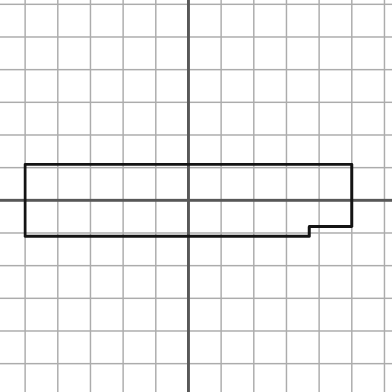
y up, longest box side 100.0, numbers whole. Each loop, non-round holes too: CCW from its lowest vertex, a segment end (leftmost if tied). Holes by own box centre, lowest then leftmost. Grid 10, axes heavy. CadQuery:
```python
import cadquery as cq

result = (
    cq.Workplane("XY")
    .moveTo(-50.0, -11.0)
    .lineTo(37.0, -11.0)
    .lineTo(37.0, -8.0)
    .lineTo(50.0, -8.0)
    .lineTo(50.0, 11.0)
    .lineTo(-50.0, 11.0)
    .close()
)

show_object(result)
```